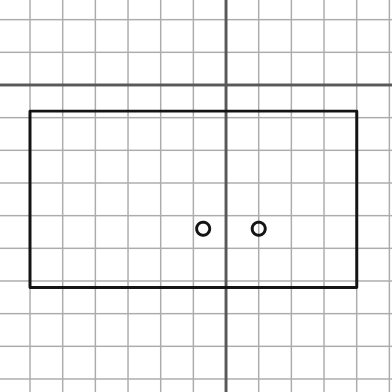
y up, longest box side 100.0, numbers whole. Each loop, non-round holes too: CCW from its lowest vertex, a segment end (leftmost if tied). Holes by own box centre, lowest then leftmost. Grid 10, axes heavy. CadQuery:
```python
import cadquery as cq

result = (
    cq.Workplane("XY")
    .moveTo(-60.0, -62.0)
    .lineTo(40.0, -62.0)
    .lineTo(40.0, -8.0)
    .lineTo(-60.0, -8.0)
    .close()
    .moveTo(-7.0, -44.0)
    .circle(2.0)
    .moveTo(10.0, -44.0)
    .circle(2.0)
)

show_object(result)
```